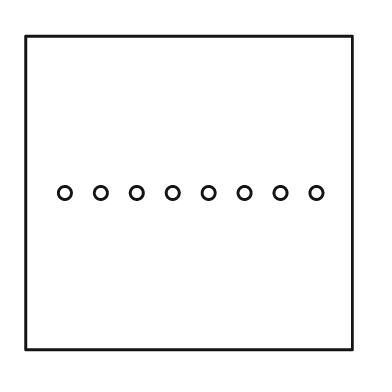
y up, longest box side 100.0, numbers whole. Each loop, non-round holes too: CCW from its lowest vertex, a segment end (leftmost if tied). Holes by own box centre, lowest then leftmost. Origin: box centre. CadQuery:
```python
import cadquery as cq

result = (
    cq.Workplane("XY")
    .moveTo(-50.0, -48.0)
    .lineTo(50.0, -48.0)
    .lineTo(50.0, 48.0)
    .lineTo(-50.0, 48.0)
    .close()
    .moveTo(-38.0, 0.0)
    .circle(2.0)
    .moveTo(-27.0, 0.0)
    .circle(2.0)
    .moveTo(-16.0, 0.0)
    .circle(2.0)
    .moveTo(-5.0, 0.0)
    .circle(2.0)
    .moveTo(6.0, 0.0)
    .circle(2.0)
    .moveTo(17.0, 0.0)
    .circle(2.0)
    .moveTo(28.0, 0.0)
    .circle(2.0)
    .moveTo(39.0, 0.0)
    .circle(2.0)
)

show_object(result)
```